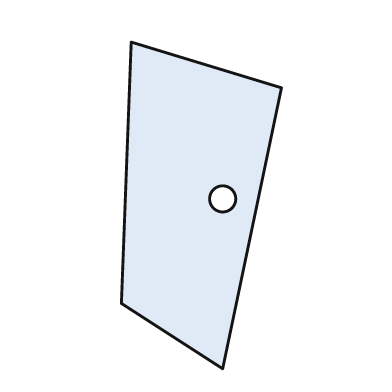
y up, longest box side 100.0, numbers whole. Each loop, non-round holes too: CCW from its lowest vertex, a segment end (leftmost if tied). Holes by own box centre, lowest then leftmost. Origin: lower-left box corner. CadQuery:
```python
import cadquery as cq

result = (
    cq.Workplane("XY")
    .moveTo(31.0, 0.0)
    .lineTo(49.0, 86.0)
    .lineTo(3.0, 100.0)
    .lineTo(0.0, 20.0)
    .close()
    .moveTo(31.0, 52.0)
    .circle(4.0)
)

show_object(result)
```